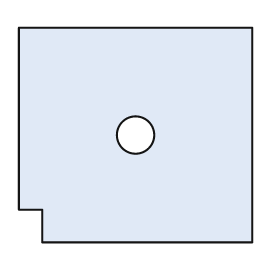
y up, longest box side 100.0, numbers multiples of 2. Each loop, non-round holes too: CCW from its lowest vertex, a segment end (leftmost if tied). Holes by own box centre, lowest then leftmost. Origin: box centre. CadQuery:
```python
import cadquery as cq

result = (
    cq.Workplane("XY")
    .moveTo(-40.0, -46.0)
    .lineTo(50.0, -46.0)
    .lineTo(50.0, 46.0)
    .lineTo(-50.0, 46.0)
    .lineTo(-50.0, -32.0)
    .lineTo(-40.0, -32.0)
    .close()
    .moveTo(0.0, 0.0)
    .circle(8.0)
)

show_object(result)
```